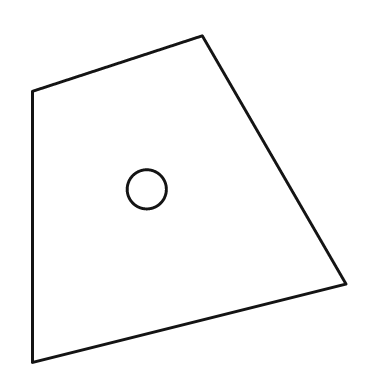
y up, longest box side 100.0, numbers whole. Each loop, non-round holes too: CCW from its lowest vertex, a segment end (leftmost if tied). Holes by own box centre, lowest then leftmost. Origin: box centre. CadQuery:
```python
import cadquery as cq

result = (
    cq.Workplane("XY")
    .moveTo(-48.0, -50.0)
    .lineTo(48.0, -26.0)
    .lineTo(4.0, 50.0)
    .lineTo(-48.0, 33.0)
    .close()
    .moveTo(-13.0, 3.0)
    .circle(6.0)
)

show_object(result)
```